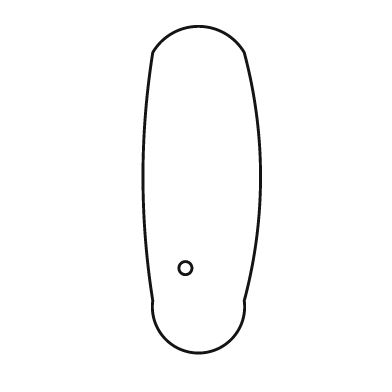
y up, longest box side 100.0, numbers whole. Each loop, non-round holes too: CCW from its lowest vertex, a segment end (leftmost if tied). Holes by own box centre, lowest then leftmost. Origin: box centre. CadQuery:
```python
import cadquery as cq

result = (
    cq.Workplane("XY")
    .moveTo(-15.0, -34.0)
    .threePointArc((-1.0, -50.0), (13.0, -34.0))
    .threePointArc((18.0, 4.0), (13.0, 42.0))
    .threePointArc((-1.0, 50.0), (-15.0, 42.0))
    .threePointArc((-18.0, 4.0), (-15.0, -34.0))
    .close()
    .moveTo(-5.0, -24.0)
    .circle(2.0)
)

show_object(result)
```